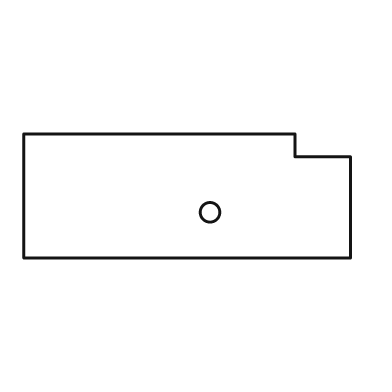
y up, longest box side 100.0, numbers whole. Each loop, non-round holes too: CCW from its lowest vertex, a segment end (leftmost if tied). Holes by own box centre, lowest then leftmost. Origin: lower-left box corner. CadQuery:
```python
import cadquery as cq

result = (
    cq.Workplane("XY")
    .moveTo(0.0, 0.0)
    .lineTo(100.0, 0.0)
    .lineTo(100.0, 31.0)
    .lineTo(83.0, 31.0)
    .lineTo(83.0, 38.0)
    .lineTo(0.0, 38.0)
    .close()
    .moveTo(57.0, 14.0)
    .circle(3.0)
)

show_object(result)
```